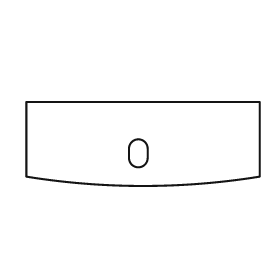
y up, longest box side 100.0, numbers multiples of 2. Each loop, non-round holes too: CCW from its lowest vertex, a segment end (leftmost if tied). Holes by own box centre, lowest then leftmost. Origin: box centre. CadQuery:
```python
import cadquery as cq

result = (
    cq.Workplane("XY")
    .moveTo(-50.0, -14.0)
    .threePointArc((0.0, -18.0), (50.0, -14.0))
    .lineTo(50.0, 18.0)
    .lineTo(-50.0, 18.0)
    .close()
    .moveTo(-6.0, -6.0)
    .threePointArc((-2.0, -10.0), (2.0, -6.0))
    .lineTo(2.0, -2.0)
    .threePointArc((-2.0, 2.0), (-6.0, -2.0))
    .close()
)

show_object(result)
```